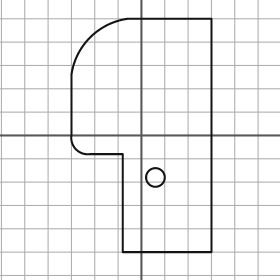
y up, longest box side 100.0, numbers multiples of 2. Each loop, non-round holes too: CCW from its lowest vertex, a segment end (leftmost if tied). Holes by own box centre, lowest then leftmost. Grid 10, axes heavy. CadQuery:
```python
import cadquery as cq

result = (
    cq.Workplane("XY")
    .moveTo(-8.0, -50.0)
    .lineTo(30.0, -50.0)
    .lineTo(30.0, 50.0)
    .lineTo(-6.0, 50.0)
    .threePointArc((-22.0, 42.0), (-30.0, 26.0))
    .lineTo(-30.0, 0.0)
    .threePointArc((-28.0, -6.0), (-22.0, -8.0))
    .lineTo(-8.0, -8.0)
    .close()
    .moveTo(6.0, -18.0)
    .circle(4.0)
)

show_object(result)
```